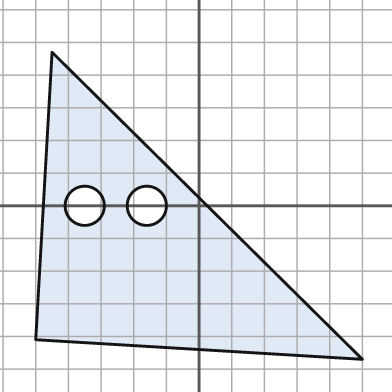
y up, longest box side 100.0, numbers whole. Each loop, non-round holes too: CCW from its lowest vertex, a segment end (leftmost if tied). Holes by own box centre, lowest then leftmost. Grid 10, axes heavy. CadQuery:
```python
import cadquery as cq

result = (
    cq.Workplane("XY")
    .moveTo(50.0, -47.0)
    .lineTo(-45.0, 47.0)
    .lineTo(-50.0, -41.0)
    .close()
    .moveTo(-35.0, 0.0)
    .circle(6.0)
    .moveTo(-16.0, 0.0)
    .circle(6.0)
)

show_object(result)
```